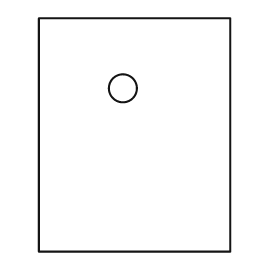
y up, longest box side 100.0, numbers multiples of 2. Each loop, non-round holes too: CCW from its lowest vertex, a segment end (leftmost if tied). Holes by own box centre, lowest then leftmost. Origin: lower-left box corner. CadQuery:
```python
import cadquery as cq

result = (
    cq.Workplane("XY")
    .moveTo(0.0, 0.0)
    .lineTo(82.0, 0.0)
    .lineTo(82.0, 100.0)
    .lineTo(0.0, 100.0)
    .close()
    .moveTo(36.0, 70.0)
    .circle(6.0)
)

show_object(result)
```